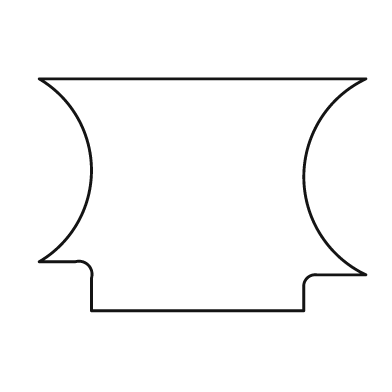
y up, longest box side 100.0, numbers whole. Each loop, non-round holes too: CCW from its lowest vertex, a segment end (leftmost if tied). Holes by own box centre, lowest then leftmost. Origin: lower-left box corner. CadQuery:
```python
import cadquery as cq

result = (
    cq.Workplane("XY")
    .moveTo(16.0, 0.0)
    .lineTo(81.0, 0.0)
    .lineTo(81.0, 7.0)
    .threePointArc((82.0, 10.0), (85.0, 11.0))
    .lineTo(100.0, 11.0)
    .threePointArc((81.0, 41.0), (100.0, 71.0))
    .lineTo(0.0, 71.0)
    .threePointArc((16.0, 43.0), (0.0, 15.0))
    .lineTo(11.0, 15.0)
    .threePointArc((15.0, 14.0), (16.0, 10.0))
    .close()
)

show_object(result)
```